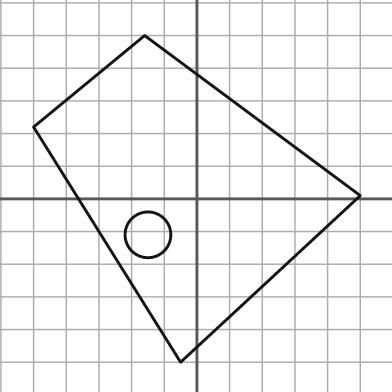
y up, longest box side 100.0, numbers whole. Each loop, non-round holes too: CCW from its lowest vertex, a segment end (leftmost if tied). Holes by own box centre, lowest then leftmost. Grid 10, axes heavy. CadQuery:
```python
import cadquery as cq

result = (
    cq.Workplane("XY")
    .moveTo(-5.0, -50.0)
    .lineTo(50.0, 1.0)
    .lineTo(-16.0, 50.0)
    .lineTo(-50.0, 22.0)
    .close()
    .moveTo(-15.0, -11.0)
    .circle(7.0)
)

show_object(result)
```